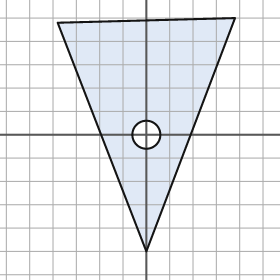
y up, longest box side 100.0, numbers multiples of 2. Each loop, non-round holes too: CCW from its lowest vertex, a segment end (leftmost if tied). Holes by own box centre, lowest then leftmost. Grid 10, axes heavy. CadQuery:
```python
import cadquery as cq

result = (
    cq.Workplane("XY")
    .moveTo(0.0, -50.0)
    .lineTo(38.0, 50.0)
    .lineTo(-38.0, 48.0)
    .close()
    .moveTo(0.0, 0.0)
    .circle(6.0)
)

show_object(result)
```